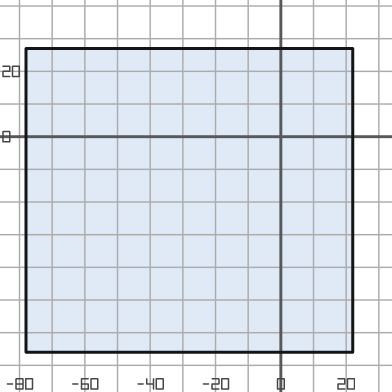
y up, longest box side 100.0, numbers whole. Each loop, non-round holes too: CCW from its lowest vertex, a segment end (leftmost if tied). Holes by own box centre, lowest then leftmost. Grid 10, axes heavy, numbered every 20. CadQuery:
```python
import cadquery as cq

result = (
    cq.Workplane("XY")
    .moveTo(-78.0, -66.0)
    .lineTo(22.0, -66.0)
    .lineTo(22.0, 27.0)
    .lineTo(-78.0, 27.0)
    .close()
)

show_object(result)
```